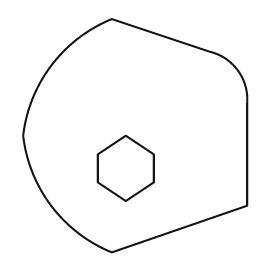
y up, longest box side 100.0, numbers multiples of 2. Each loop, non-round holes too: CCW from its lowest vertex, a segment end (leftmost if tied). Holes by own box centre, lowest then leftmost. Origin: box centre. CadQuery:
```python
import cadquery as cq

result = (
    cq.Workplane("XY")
    .moveTo(-10.0, -50.0)
    .lineTo(48.0, -30.0)
    .lineTo(48.0, 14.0)
    .threePointArc((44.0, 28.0), (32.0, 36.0))
    .lineTo(-10.0, 50.0)
    .threePointArc((-36.0, 30.0), (-48.0, 0.0))
    .threePointArc((-36.0, -30.0), (-10.0, -50.0))
    .close()
    .moveTo(-4.0, -28.0)
    .lineTo(8.0, -20.0)
    .lineTo(8.0, -8.0)
    .lineTo(-4.0, 0.0)
    .lineTo(-16.0, -8.0)
    .lineTo(-16.0, -20.0)
    .close()
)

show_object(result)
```